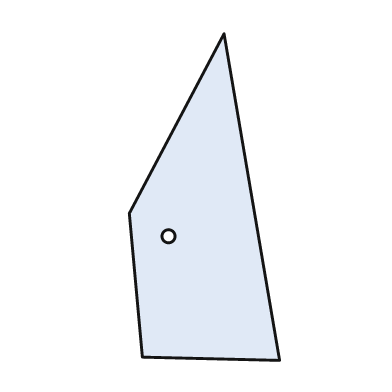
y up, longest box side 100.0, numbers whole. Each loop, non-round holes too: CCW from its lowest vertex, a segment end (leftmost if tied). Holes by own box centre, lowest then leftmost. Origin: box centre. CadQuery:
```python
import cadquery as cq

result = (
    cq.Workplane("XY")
    .moveTo(23.0, -50.0)
    .lineTo(6.0, 50.0)
    .lineTo(-23.0, -5.0)
    .lineTo(-19.0, -49.0)
    .close()
    .moveTo(-11.0, -12.0)
    .circle(2.0)
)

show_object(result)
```